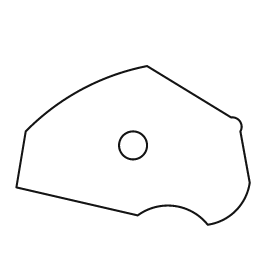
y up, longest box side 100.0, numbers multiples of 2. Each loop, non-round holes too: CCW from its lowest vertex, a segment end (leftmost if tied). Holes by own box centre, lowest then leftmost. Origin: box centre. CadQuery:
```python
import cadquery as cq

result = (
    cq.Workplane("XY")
    .moveTo(32.0, -34.0)
    .threePointArc((44.0, -28.0), (50.0, -16.0))
    .lineTo(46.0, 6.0)
    .threePointArc((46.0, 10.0), (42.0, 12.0))
    .lineTo(6.0, 34.0)
    .threePointArc((-22.0, 24.0), (-46.0, 6.0))
    .lineTo(-50.0, -18.0)
    .lineTo(2.0, -30.0)
    .threePointArc((18.0, -26.0), (32.0, -34.0))
    .close()
    .moveTo(0.0, 0.0)
    .circle(6.0)
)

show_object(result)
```